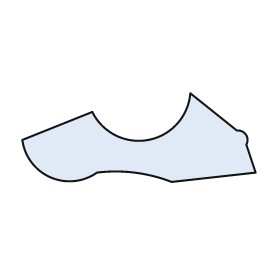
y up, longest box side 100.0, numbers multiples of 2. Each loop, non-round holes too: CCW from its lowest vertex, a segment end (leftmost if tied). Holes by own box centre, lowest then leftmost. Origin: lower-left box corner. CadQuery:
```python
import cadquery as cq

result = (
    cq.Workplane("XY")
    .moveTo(64.0, 0.0)
    .lineTo(100.0, 4.0)
    .lineTo(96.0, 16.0)
    .threePointArc((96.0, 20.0), (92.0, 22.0))
    .lineTo(72.0, 38.0)
    .threePointArc((54.0, 18.0), (30.0, 30.0))
    .lineTo(0.0, 18.0)
    .threePointArc((12.0, 2.0), (32.0, 4.0))
    .threePointArc((48.0, 4.0), (64.0, 0.0))
    .close()
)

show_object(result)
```